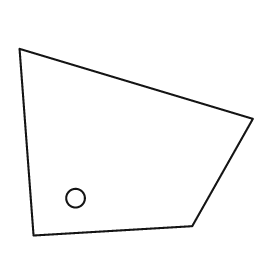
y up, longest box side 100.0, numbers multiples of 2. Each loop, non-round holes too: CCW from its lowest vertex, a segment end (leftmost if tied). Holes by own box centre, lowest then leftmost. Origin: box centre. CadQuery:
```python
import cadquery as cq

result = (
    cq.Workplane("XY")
    .moveTo(-44.0, -40.0)
    .lineTo(24.0, -36.0)
    .lineTo(50.0, 10.0)
    .lineTo(-50.0, 40.0)
    .close()
    .moveTo(-26.0, -24.0)
    .circle(4.0)
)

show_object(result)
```